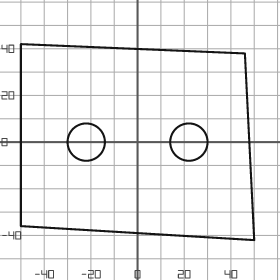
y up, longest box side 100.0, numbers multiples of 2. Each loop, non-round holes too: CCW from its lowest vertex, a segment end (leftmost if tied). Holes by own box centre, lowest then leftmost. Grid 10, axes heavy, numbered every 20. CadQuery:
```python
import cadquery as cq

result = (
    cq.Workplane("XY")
    .moveTo(50.0, -42.0)
    .lineTo(46.0, 38.0)
    .lineTo(-50.0, 42.0)
    .lineTo(-50.0, -36.0)
    .close()
    .moveTo(-22.0, 0.0)
    .circle(8.0)
    .moveTo(22.0, 0.0)
    .circle(8.0)
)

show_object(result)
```